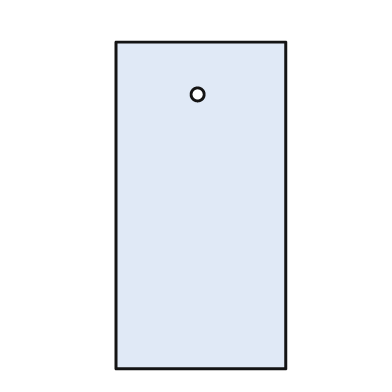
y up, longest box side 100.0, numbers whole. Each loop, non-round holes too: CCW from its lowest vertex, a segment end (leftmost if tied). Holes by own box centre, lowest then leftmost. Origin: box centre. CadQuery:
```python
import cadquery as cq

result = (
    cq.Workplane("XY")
    .moveTo(-26.0, -50.0)
    .lineTo(26.0, -50.0)
    .lineTo(26.0, 50.0)
    .lineTo(-26.0, 50.0)
    .close()
    .moveTo(-1.0, 34.0)
    .circle(2.0)
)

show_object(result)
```